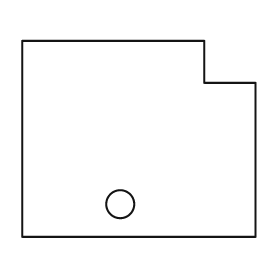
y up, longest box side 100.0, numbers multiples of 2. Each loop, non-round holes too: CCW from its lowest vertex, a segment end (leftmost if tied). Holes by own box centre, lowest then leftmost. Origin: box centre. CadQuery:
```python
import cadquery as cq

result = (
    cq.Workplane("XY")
    .moveTo(-50.0, -42.0)
    .lineTo(50.0, -42.0)
    .lineTo(50.0, 24.0)
    .lineTo(28.0, 24.0)
    .lineTo(28.0, 42.0)
    .lineTo(-50.0, 42.0)
    .close()
    .moveTo(-8.0, -28.0)
    .circle(6.0)
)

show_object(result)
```